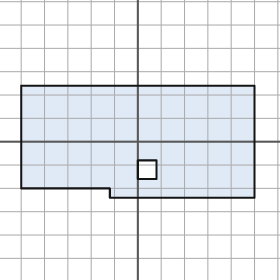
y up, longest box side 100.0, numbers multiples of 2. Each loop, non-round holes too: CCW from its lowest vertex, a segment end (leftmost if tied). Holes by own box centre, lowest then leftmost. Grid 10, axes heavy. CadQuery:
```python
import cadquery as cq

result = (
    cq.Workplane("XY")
    .moveTo(-12.0, -24.0)
    .lineTo(50.0, -24.0)
    .lineTo(50.0, 24.0)
    .lineTo(-50.0, 24.0)
    .lineTo(-50.0, -20.0)
    .lineTo(-12.0, -20.0)
    .close()
    .moveTo(0.0, -16.0)
    .lineTo(8.0, -16.0)
    .lineTo(8.0, -8.0)
    .lineTo(0.0, -8.0)
    .close()
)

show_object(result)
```